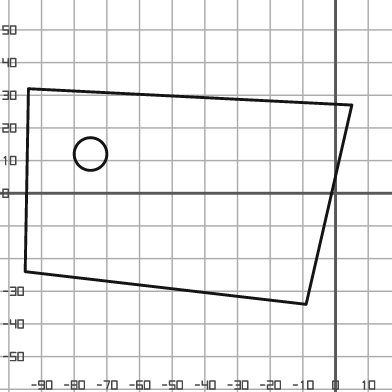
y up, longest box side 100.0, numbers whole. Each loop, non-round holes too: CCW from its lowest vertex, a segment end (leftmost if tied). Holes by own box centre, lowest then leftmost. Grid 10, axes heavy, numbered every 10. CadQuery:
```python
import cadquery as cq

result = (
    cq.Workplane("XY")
    .moveTo(-9.0, -34.0)
    .lineTo(5.0, 27.0)
    .lineTo(-94.0, 32.0)
    .lineTo(-95.0, -24.0)
    .close()
    .moveTo(-75.0, 12.0)
    .circle(5.0)
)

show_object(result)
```